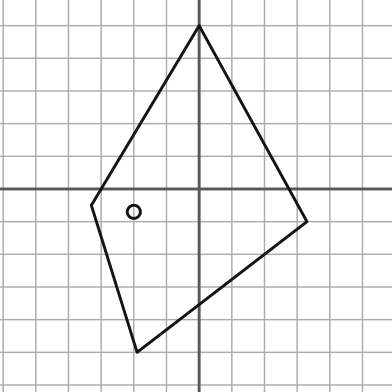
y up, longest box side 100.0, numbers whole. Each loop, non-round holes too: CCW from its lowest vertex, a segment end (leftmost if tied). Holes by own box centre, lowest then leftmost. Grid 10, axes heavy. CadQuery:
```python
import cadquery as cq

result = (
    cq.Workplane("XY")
    .moveTo(-19.0, -50.0)
    .lineTo(33.0, -10.0)
    .lineTo(0.0, 50.0)
    .lineTo(-33.0, -5.0)
    .close()
    .moveTo(-20.0, -7.0)
    .circle(2.0)
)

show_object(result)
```